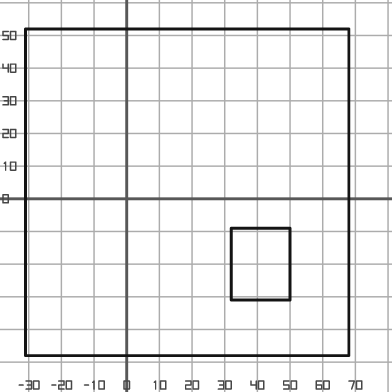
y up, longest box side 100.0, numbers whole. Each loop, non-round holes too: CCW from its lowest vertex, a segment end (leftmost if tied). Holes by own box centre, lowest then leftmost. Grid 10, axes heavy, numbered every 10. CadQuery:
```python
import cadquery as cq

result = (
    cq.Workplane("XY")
    .moveTo(-31.0, -48.0)
    .lineTo(68.0, -48.0)
    .lineTo(68.0, 52.0)
    .lineTo(-31.0, 52.0)
    .close()
    .moveTo(32.0, -31.0)
    .lineTo(50.0, -31.0)
    .lineTo(50.0, -9.0)
    .lineTo(32.0, -9.0)
    .close()
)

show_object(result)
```